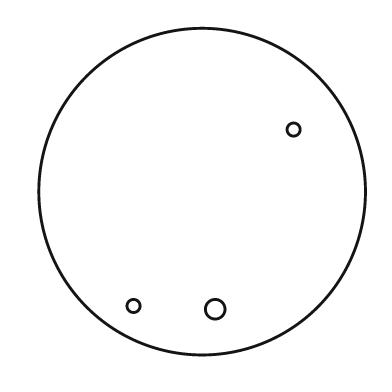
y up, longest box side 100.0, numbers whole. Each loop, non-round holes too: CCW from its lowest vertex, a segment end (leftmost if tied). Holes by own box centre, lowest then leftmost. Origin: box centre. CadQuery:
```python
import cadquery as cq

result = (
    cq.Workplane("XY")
    .moveTo(0.0, 0.0)
    .circle(50.0)
    .moveTo(4.0, -36.0)
    .circle(3.0)
    .moveTo(-21.0, -35.0)
    .circle(2.0)
    .moveTo(28.0, 19.0)
    .circle(2.0)
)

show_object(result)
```